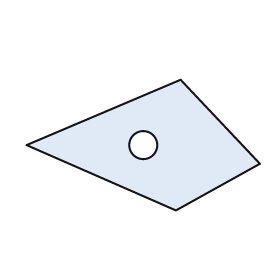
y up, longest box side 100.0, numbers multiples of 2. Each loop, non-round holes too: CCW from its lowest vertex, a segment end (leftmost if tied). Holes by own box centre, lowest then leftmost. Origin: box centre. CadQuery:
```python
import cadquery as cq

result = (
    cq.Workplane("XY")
    .moveTo(14.0, -28.0)
    .lineTo(50.0, -8.0)
    .lineTo(16.0, 28.0)
    .lineTo(-50.0, 0.0)
    .close()
    .moveTo(0.0, 0.0)
    .circle(6.0)
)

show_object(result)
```